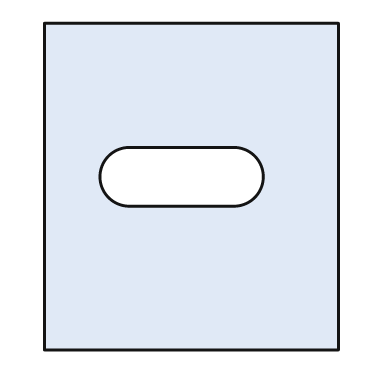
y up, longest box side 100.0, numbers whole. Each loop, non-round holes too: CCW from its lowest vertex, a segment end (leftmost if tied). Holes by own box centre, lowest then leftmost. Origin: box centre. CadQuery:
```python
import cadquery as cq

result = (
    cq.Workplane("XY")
    .moveTo(-45.0, -50.0)
    .lineTo(45.0, -50.0)
    .lineTo(45.0, 50.0)
    .lineTo(-45.0, 50.0)
    .close()
    .moveTo(-19.0, -6.0)
    .lineTo(13.0, -6.0)
    .threePointArc((22.0, 3.0), (13.0, 12.0))
    .lineTo(-19.0, 12.0)
    .threePointArc((-28.0, 3.0), (-19.0, -6.0))
    .close()
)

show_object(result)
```